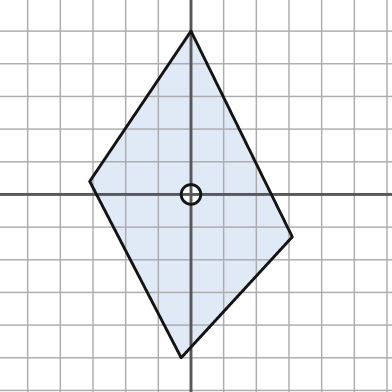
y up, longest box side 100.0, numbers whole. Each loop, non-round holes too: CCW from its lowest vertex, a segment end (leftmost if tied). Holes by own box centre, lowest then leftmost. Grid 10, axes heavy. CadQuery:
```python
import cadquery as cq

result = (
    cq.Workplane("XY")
    .moveTo(-3.0, -50.0)
    .lineTo(31.0, -13.0)
    .lineTo(0.0, 50.0)
    .lineTo(-31.0, 4.0)
    .close()
    .moveTo(0.0, 0.0)
    .circle(3.0)
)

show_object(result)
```